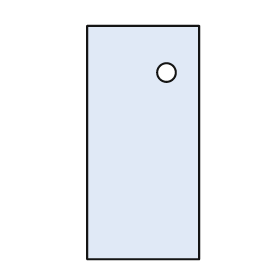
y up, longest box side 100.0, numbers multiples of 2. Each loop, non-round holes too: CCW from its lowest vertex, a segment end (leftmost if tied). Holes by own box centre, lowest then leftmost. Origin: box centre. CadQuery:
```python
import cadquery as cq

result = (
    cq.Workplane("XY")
    .moveTo(-24.0, -50.0)
    .lineTo(24.0, -50.0)
    .lineTo(24.0, 50.0)
    .lineTo(-24.0, 50.0)
    .close()
    .moveTo(10.0, 30.0)
    .circle(4.0)
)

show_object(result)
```